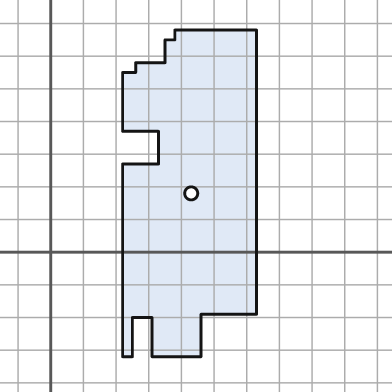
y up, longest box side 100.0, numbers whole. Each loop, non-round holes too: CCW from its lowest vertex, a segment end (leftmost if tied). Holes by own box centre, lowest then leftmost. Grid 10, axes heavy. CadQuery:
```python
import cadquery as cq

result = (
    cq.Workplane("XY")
    .moveTo(22.0, -32.0)
    .lineTo(25.0, -32.0)
    .lineTo(25.0, -20.0)
    .lineTo(31.0, -20.0)
    .lineTo(31.0, -32.0)
    .lineTo(46.0, -32.0)
    .lineTo(46.0, -19.0)
    .lineTo(63.0, -19.0)
    .lineTo(63.0, 68.0)
    .lineTo(38.0, 68.0)
    .lineTo(38.0, 65.0)
    .lineTo(35.0, 65.0)
    .lineTo(35.0, 58.0)
    .lineTo(26.0, 58.0)
    .lineTo(26.0, 55.0)
    .lineTo(22.0, 55.0)
    .lineTo(22.0, 37.0)
    .lineTo(33.0, 37.0)
    .lineTo(33.0, 27.0)
    .lineTo(22.0, 27.0)
    .close()
    .moveTo(43.0, 18.0)
    .circle(2.0)
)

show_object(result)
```